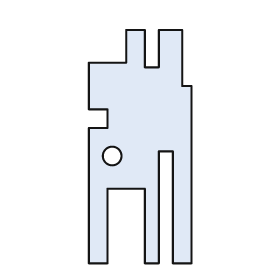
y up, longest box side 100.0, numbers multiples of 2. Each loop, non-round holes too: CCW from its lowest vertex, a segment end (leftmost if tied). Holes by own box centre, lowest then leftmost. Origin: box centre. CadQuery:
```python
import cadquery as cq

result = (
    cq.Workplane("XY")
    .moveTo(-22.0, -50.0)
    .lineTo(-14.0, -50.0)
    .lineTo(-14.0, -18.0)
    .lineTo(2.0, -18.0)
    .lineTo(2.0, -50.0)
    .lineTo(8.0, -50.0)
    .lineTo(8.0, -2.0)
    .lineTo(14.0, -2.0)
    .lineTo(14.0, -50.0)
    .lineTo(22.0, -50.0)
    .lineTo(22.0, 26.0)
    .lineTo(18.0, 26.0)
    .lineTo(18.0, 50.0)
    .lineTo(8.0, 50.0)
    .lineTo(8.0, 34.0)
    .lineTo(2.0, 34.0)
    .lineTo(2.0, 50.0)
    .lineTo(-6.0, 50.0)
    .lineTo(-6.0, 36.0)
    .lineTo(-22.0, 36.0)
    .lineTo(-22.0, 16.0)
    .lineTo(-14.0, 16.0)
    .lineTo(-14.0, 8.0)
    .lineTo(-22.0, 8.0)
    .close()
    .moveTo(-12.0, -4.0)
    .circle(4.0)
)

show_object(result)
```